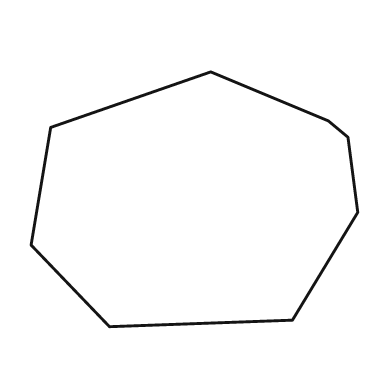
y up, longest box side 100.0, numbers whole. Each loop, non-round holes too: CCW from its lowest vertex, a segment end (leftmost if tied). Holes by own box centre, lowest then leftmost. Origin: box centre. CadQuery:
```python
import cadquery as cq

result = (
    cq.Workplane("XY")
    .moveTo(-26.0, -39.0)
    .lineTo(30.0, -37.0)
    .lineTo(50.0, -4.0)
    .lineTo(47.0, 19.0)
    .lineTo(41.0, 24.0)
    .lineTo(5.0, 39.0)
    .lineTo(-44.0, 22.0)
    .lineTo(-50.0, -14.0)
    .close()
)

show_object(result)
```